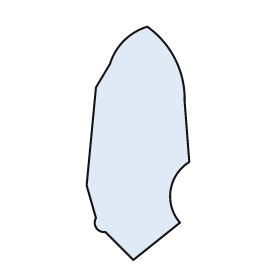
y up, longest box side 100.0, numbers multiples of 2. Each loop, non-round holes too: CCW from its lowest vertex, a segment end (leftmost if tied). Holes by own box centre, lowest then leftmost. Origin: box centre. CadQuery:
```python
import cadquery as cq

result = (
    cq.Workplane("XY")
    .moveTo(-2.0, -50.0)
    .lineTo(18.0, -34.0)
    .threePointArc((14.0, -20.0), (22.0, -8.0))
    .lineTo(20.0, 18.0)
    .threePointArc((16.0, 36.0), (4.0, 50.0))
    .threePointArc((-6.0, 44.0), (-12.0, 34.0))
    .lineTo(-18.0, 24.0)
    .lineTo(-22.0, -18.0)
    .lineTo(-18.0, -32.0)
    .threePointArc((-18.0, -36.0), (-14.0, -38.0))
    .close()
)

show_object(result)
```